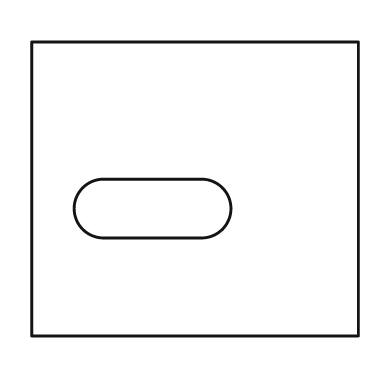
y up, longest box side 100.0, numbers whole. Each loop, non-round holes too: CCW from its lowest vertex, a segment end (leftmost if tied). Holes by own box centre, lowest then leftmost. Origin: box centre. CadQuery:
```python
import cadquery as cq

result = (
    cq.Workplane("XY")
    .moveTo(-50.0, -45.0)
    .lineTo(50.0, -45.0)
    .lineTo(50.0, 45.0)
    .lineTo(-50.0, 45.0)
    .close()
    .moveTo(-28.0, -15.0)
    .lineTo(2.0, -15.0)
    .threePointArc((11.0, -6.0), (2.0, 3.0))
    .lineTo(-28.0, 3.0)
    .threePointArc((-37.0, -6.0), (-28.0, -15.0))
    .close()
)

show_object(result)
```